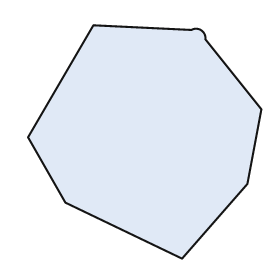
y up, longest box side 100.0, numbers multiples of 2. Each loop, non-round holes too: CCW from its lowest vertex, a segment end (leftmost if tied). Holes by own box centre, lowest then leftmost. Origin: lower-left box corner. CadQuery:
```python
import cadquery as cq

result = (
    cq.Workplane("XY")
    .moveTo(66.0, 0.0)
    .lineTo(94.0, 32.0)
    .lineTo(100.0, 64.0)
    .lineTo(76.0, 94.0)
    .threePointArc((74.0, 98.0), (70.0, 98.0))
    .lineTo(28.0, 100.0)
    .lineTo(0.0, 52.0)
    .lineTo(16.0, 24.0)
    .close()
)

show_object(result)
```